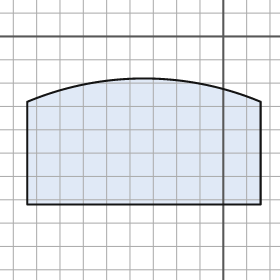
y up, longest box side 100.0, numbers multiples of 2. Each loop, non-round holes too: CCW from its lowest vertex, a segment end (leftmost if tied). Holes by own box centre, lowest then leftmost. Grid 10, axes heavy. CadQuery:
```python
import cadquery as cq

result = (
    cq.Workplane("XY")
    .moveTo(-84.0, -72.0)
    .lineTo(16.0, -72.0)
    .lineTo(16.0, -28.0)
    .threePointArc((-34.0, -18.0), (-84.0, -28.0))
    .close()
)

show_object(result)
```